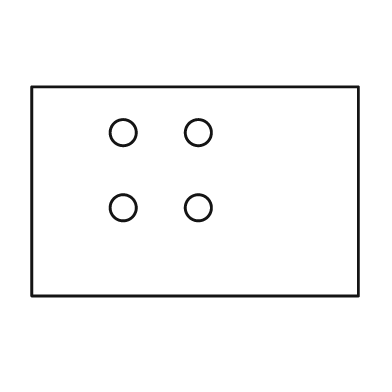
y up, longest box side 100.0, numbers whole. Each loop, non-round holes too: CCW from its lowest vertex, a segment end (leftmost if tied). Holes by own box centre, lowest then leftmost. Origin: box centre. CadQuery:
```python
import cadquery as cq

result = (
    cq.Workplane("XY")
    .moveTo(-50.0, -32.0)
    .lineTo(50.0, -32.0)
    .lineTo(50.0, 32.0)
    .lineTo(-50.0, 32.0)
    .close()
    .moveTo(-22.0, -5.0)
    .circle(4.0)
    .moveTo(1.0, -5.0)
    .circle(4.0)
    .moveTo(-22.0, 18.0)
    .circle(4.0)
    .moveTo(1.0, 18.0)
    .circle(4.0)
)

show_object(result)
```